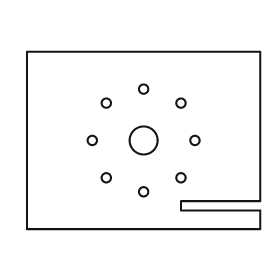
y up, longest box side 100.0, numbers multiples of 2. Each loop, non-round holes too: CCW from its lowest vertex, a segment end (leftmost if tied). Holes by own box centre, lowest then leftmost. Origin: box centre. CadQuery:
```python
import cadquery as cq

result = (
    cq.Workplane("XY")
    .moveTo(-50.0, -38.0)
    .lineTo(50.0, -38.0)
    .lineTo(50.0, -30.0)
    .lineTo(16.0, -30.0)
    .lineTo(16.0, -26.0)
    .lineTo(50.0, -26.0)
    .lineTo(50.0, 38.0)
    .lineTo(-50.0, 38.0)
    .close()
    .moveTo(0.0, -22.0)
    .circle(2.0)
    .moveTo(-16.0, -16.0)
    .circle(2.0)
    .moveTo(16.0, -16.0)
    .circle(2.0)
    .moveTo(-22.0, 0.0)
    .circle(2.0)
    .moveTo(0.0, 0.0)
    .circle(6.0)
    .moveTo(22.0, 0.0)
    .circle(2.0)
    .moveTo(-16.0, 16.0)
    .circle(2.0)
    .moveTo(16.0, 16.0)
    .circle(2.0)
    .moveTo(0.0, 22.0)
    .circle(2.0)
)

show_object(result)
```